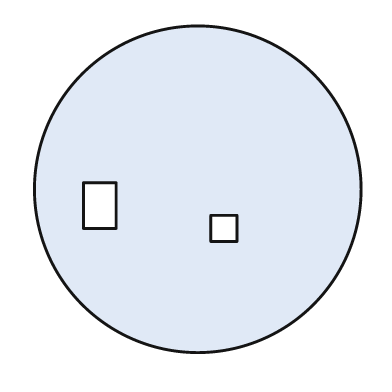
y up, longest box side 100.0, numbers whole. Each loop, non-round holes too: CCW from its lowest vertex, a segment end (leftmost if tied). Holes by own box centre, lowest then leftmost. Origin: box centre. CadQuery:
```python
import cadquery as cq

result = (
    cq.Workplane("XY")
    .moveTo(0.0, 0.0)
    .circle(50.0)
    .moveTo(4.0, -16.0)
    .lineTo(12.0, -16.0)
    .lineTo(12.0, -8.0)
    .lineTo(4.0, -8.0)
    .close()
    .moveTo(-35.0, -12.0)
    .lineTo(-25.0, -12.0)
    .lineTo(-25.0, 2.0)
    .lineTo(-35.0, 2.0)
    .close()
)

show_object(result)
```